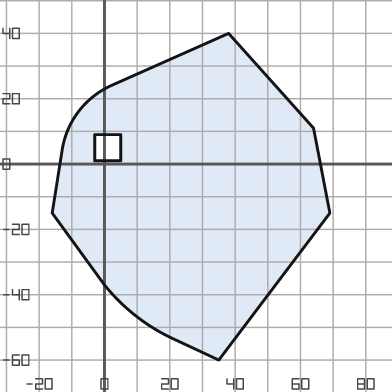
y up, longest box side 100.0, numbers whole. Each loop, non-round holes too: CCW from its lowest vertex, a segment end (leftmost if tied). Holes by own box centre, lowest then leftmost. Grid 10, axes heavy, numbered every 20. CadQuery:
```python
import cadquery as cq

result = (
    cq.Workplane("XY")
    .moveTo(35.0, -60.0)
    .lineTo(69.0, -15.0)
    .lineTo(64.0, 11.0)
    .lineTo(38.0, 40.0)
    .lineTo(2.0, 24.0)
    .threePointArc((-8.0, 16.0), (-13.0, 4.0))
    .lineTo(-16.0, -15.0)
    .lineTo(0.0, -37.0)
    .threePointArc((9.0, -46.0), (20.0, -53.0))
    .close()
    .moveTo(-3.0, 1.0)
    .lineTo(5.0, 1.0)
    .lineTo(5.0, 9.0)
    .lineTo(-3.0, 9.0)
    .close()
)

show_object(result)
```